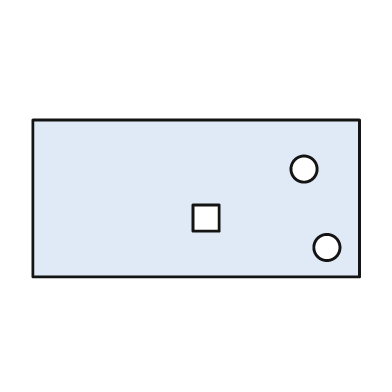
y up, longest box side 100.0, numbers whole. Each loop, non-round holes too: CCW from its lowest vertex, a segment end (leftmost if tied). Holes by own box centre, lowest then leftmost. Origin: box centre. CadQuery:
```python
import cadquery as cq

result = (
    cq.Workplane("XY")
    .moveTo(-50.0, -24.0)
    .lineTo(50.0, -24.0)
    .lineTo(50.0, 24.0)
    .lineTo(-50.0, 24.0)
    .close()
    .moveTo(40.0, -15.0)
    .circle(4.0)
    .moveTo(-1.0, -10.0)
    .lineTo(7.0, -10.0)
    .lineTo(7.0, -2.0)
    .lineTo(-1.0, -2.0)
    .close()
    .moveTo(33.0, 9.0)
    .circle(4.0)
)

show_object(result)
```